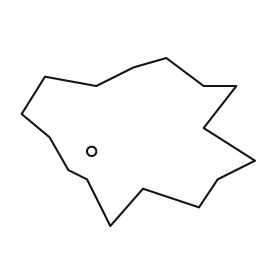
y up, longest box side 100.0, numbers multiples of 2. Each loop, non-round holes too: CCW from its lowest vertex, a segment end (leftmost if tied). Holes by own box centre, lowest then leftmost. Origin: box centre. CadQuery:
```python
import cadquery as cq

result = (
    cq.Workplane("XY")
    .moveTo(-12.0, -36.0)
    .lineTo(2.0, -20.0)
    .lineTo(26.0, -28.0)
    .lineTo(34.0, -16.0)
    .lineTo(50.0, -8.0)
    .lineTo(28.0, 6.0)
    .lineTo(42.0, 24.0)
    .lineTo(28.0, 24.0)
    .lineTo(12.0, 36.0)
    .lineTo(-2.0, 32.0)
    .lineTo(-18.0, 24.0)
    .lineTo(-40.0, 28.0)
    .lineTo(-50.0, 12.0)
    .lineTo(-38.0, 2.0)
    .lineTo(-30.0, -12.0)
    .lineTo(-22.0, -16.0)
    .close()
    .moveTo(-20.0, -4.0)
    .circle(2.0)
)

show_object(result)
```